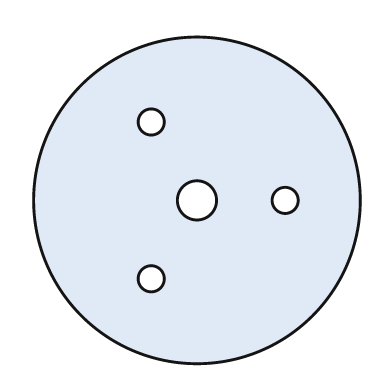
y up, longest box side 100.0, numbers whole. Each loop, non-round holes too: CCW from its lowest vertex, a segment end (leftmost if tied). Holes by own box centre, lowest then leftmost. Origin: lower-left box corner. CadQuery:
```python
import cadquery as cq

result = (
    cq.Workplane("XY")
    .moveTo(50.0, 50.0)
    .circle(50.0)
    .moveTo(36.0, 26.0)
    .circle(4.0)
    .moveTo(50.0, 50.0)
    .circle(6.0)
    .moveTo(77.0, 50.0)
    .circle(4.0)
    .moveTo(36.0, 74.0)
    .circle(4.0)
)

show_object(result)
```